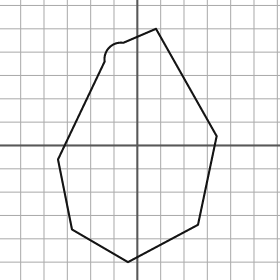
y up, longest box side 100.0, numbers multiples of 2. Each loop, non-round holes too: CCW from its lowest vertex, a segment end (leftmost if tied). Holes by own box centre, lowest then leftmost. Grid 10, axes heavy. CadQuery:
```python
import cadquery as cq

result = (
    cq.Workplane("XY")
    .moveTo(-4.0, -50.0)
    .lineTo(26.0, -34.0)
    .lineTo(34.0, 4.0)
    .lineTo(8.0, 50.0)
    .lineTo(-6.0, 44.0)
    .threePointArc((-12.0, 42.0), (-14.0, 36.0))
    .lineTo(-34.0, -6.0)
    .lineTo(-28.0, -36.0)
    .close()
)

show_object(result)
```